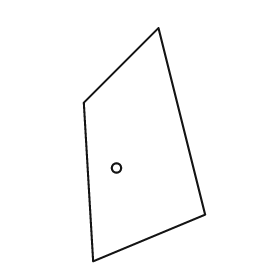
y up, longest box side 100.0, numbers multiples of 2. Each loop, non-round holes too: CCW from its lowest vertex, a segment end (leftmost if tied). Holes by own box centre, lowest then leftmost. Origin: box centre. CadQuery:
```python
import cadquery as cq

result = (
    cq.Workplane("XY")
    .moveTo(-22.0, -50.0)
    .lineTo(26.0, -30.0)
    .lineTo(6.0, 50.0)
    .lineTo(-26.0, 18.0)
    .close()
    .moveTo(-12.0, -10.0)
    .circle(2.0)
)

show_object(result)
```